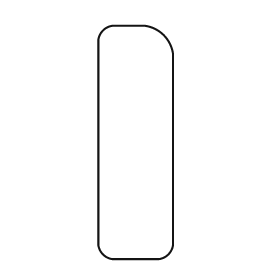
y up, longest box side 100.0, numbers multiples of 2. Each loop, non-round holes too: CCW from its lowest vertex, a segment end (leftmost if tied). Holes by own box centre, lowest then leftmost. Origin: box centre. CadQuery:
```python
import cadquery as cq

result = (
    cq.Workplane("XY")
    .moveTo(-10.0, -50.0)
    .lineTo(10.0, -50.0)
    .threePointArc((14.0, -48.0), (16.0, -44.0))
    .lineTo(16.0, 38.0)
    .threePointArc((12.0, 46.0), (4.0, 50.0))
    .lineTo(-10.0, 50.0)
    .threePointArc((-14.0, 48.0), (-16.0, 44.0))
    .lineTo(-16.0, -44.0)
    .threePointArc((-14.0, -48.0), (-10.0, -50.0))
    .close()
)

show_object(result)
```